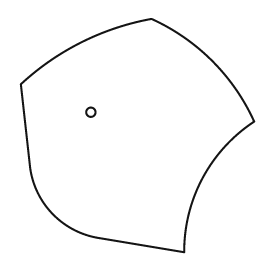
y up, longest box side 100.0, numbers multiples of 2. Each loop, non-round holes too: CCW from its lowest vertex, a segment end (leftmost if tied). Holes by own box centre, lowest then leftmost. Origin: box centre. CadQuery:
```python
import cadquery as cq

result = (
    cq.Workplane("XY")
    .moveTo(20.0, -50.0)
    .threePointArc((28.0, -18.0), (50.0, 6.0))
    .threePointArc((32.0, 32.0), (6.0, 50.0))
    .threePointArc((-24.0, 40.0), (-50.0, 22.0))
    .lineTo(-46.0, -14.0)
    .threePointArc((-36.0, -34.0), (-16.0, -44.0))
    .close()
    .moveTo(-20.0, 10.0)
    .circle(2.0)
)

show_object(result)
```